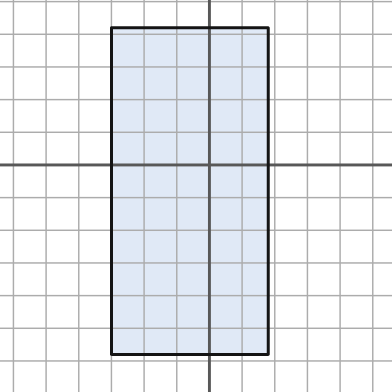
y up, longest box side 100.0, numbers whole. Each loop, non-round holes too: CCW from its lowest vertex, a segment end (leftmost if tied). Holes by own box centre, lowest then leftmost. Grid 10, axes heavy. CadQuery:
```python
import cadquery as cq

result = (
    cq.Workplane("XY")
    .moveTo(-30.0, -58.0)
    .lineTo(18.0, -58.0)
    .lineTo(18.0, 42.0)
    .lineTo(-30.0, 42.0)
    .close()
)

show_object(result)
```